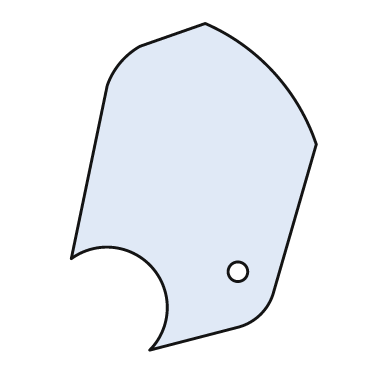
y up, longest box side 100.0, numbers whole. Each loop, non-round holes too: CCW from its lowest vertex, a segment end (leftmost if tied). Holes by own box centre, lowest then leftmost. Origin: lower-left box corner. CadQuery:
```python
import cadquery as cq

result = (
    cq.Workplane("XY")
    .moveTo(24.0, 0.0)
    .lineTo(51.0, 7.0)
    .threePointArc((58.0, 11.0), (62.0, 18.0))
    .lineTo(75.0, 63.0)
    .threePointArc((62.0, 85.0), (41.0, 100.0))
    .lineTo(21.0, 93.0)
    .threePointArc((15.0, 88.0), (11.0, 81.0))
    .lineTo(0.0, 28.0)
    .threePointArc((25.0, 25.0), (24.0, 0.0))
    .close()
    .moveTo(51.0, 24.0)
    .circle(3.0)
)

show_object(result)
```